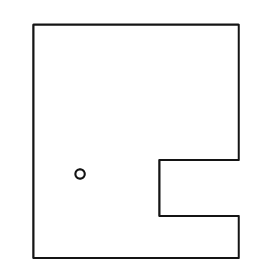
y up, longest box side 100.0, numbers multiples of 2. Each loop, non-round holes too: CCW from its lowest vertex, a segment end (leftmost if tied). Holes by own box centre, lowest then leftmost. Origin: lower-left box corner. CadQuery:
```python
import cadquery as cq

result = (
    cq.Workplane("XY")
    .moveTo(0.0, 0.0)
    .lineTo(88.0, 0.0)
    .lineTo(88.0, 18.0)
    .lineTo(54.0, 18.0)
    .lineTo(54.0, 42.0)
    .lineTo(88.0, 42.0)
    .lineTo(88.0, 100.0)
    .lineTo(0.0, 100.0)
    .close()
    .moveTo(20.0, 36.0)
    .circle(2.0)
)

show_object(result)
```